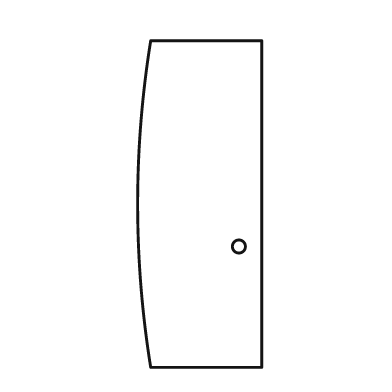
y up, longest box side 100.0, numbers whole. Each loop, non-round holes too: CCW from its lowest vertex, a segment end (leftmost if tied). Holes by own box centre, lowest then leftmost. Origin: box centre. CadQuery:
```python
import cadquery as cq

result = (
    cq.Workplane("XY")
    .moveTo(-15.0, -50.0)
    .lineTo(19.0, -50.0)
    .lineTo(19.0, 50.0)
    .lineTo(-15.0, 50.0)
    .threePointArc((-19.0, 0.0), (-15.0, -50.0))
    .close()
    .moveTo(12.0, -13.0)
    .circle(2.0)
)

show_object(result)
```